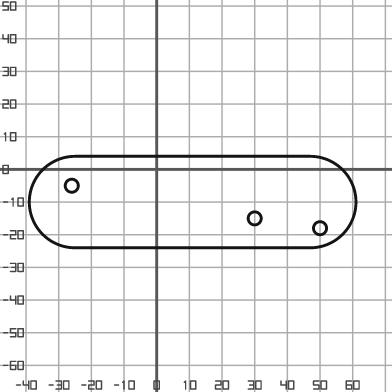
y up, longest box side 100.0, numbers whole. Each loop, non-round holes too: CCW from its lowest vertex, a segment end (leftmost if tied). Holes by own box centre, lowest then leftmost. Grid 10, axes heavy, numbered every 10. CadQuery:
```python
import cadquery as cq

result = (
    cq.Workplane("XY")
    .moveTo(-25.0, -24.0)
    .lineTo(47.0, -24.0)
    .threePointArc((61.0, -10.0), (47.0, 4.0))
    .lineTo(-25.0, 4.0)
    .threePointArc((-39.0, -10.0), (-25.0, -24.0))
    .close()
    .moveTo(50.0, -18.0)
    .circle(2.0)
    .moveTo(30.0, -15.0)
    .circle(2.0)
    .moveTo(-26.0, -5.0)
    .circle(2.0)
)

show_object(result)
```